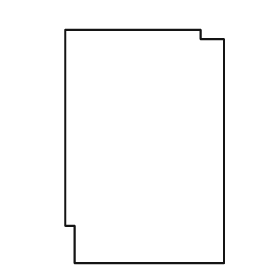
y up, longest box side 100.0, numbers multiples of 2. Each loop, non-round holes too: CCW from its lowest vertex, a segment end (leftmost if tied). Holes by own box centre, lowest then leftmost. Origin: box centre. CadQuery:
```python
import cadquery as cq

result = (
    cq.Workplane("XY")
    .moveTo(-30.0, -50.0)
    .lineTo(34.0, -50.0)
    .lineTo(34.0, 46.0)
    .lineTo(24.0, 46.0)
    .lineTo(24.0, 50.0)
    .lineTo(-34.0, 50.0)
    .lineTo(-34.0, -34.0)
    .lineTo(-30.0, -34.0)
    .close()
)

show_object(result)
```